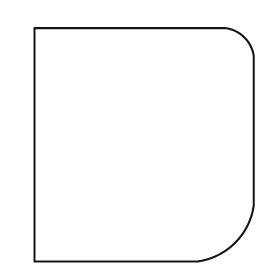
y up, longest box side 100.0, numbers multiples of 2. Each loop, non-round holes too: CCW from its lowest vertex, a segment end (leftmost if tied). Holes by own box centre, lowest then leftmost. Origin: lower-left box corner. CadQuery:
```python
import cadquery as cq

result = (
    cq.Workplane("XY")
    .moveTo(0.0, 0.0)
    .lineTo(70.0, 0.0)
    .threePointArc((86.0, 8.0), (94.0, 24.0))
    .lineTo(94.0, 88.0)
    .threePointArc((90.0, 96.0), (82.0, 100.0))
    .lineTo(0.0, 100.0)
    .close()
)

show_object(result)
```